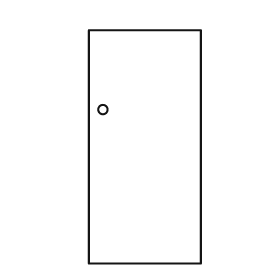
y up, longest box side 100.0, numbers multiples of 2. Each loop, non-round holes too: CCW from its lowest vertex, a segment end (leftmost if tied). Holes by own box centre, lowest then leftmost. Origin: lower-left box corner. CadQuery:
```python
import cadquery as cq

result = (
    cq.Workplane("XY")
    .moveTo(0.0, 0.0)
    .lineTo(48.0, 0.0)
    .lineTo(48.0, 100.0)
    .lineTo(0.0, 100.0)
    .close()
    .moveTo(6.0, 66.0)
    .circle(2.0)
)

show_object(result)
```